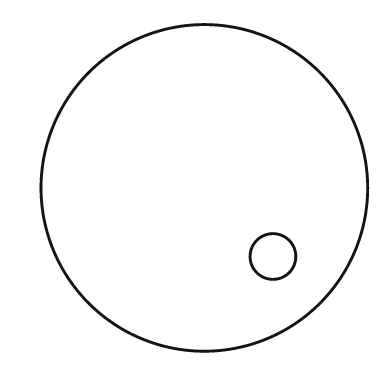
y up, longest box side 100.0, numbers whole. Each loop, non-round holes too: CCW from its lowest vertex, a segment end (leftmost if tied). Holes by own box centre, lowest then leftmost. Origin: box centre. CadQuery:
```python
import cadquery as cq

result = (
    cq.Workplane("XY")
    .moveTo(0.0, 0.0)
    .circle(50.0)
    .moveTo(21.0, -21.0)
    .circle(7.0)
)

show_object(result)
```